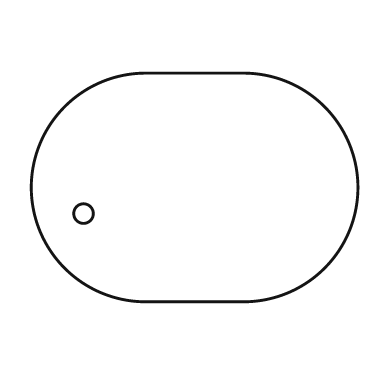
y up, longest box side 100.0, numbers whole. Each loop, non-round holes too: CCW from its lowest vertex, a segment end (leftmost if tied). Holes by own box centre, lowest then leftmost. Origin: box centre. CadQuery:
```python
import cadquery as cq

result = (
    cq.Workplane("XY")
    .moveTo(-15.0, -35.0)
    .lineTo(15.0, -35.0)
    .threePointArc((50.0, 0.0), (15.0, 35.0))
    .lineTo(-15.0, 35.0)
    .threePointArc((-50.0, 0.0), (-15.0, -35.0))
    .close()
    .moveTo(-34.0, -8.0)
    .circle(3.0)
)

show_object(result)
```